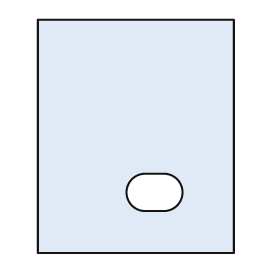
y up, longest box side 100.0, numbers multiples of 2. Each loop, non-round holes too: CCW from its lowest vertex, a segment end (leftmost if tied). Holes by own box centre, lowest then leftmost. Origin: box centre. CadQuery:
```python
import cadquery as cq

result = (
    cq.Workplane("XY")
    .moveTo(-42.0, -50.0)
    .lineTo(42.0, -50.0)
    .lineTo(42.0, 50.0)
    .lineTo(-42.0, 50.0)
    .close()
    .moveTo(4.0, -32.0)
    .lineTo(12.0, -32.0)
    .threePointArc((20.0, -24.0), (12.0, -16.0))
    .lineTo(4.0, -16.0)
    .threePointArc((-4.0, -24.0), (4.0, -32.0))
    .close()
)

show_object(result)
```